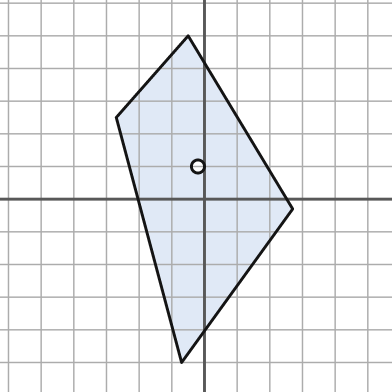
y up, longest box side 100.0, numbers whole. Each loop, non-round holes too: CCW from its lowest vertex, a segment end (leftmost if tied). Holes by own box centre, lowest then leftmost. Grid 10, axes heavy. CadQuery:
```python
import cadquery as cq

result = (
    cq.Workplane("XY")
    .moveTo(-7.0, -50.0)
    .lineTo(27.0, -3.0)
    .lineTo(-5.0, 50.0)
    .lineTo(-27.0, 25.0)
    .close()
    .moveTo(-2.0, 10.0)
    .circle(2.0)
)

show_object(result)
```